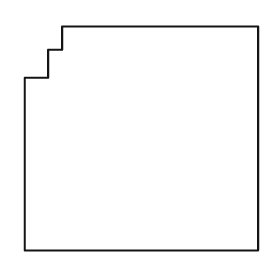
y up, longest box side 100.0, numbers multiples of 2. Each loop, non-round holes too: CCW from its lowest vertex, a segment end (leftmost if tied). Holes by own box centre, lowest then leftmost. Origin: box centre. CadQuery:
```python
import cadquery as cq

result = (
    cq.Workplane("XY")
    .moveTo(-50.0, -48.0)
    .lineTo(50.0, -48.0)
    .lineTo(50.0, 48.0)
    .lineTo(-34.0, 48.0)
    .lineTo(-34.0, 38.0)
    .lineTo(-40.0, 38.0)
    .lineTo(-40.0, 26.0)
    .lineTo(-50.0, 26.0)
    .close()
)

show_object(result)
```